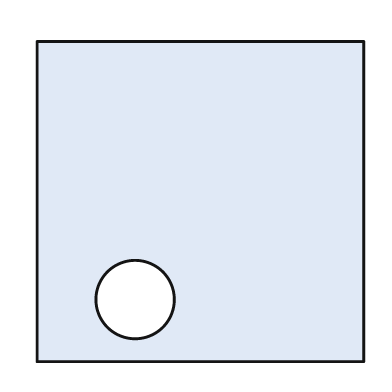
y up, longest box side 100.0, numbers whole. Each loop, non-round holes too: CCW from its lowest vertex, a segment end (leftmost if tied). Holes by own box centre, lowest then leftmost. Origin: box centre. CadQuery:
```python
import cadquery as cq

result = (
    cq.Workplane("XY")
    .moveTo(-50.0, -49.0)
    .lineTo(50.0, -49.0)
    .lineTo(50.0, 49.0)
    .lineTo(-50.0, 49.0)
    .close()
    .moveTo(-20.0, -30.0)
    .circle(12.0)
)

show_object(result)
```